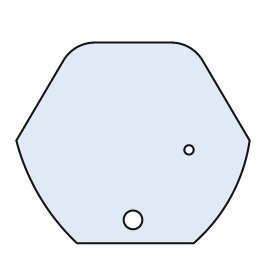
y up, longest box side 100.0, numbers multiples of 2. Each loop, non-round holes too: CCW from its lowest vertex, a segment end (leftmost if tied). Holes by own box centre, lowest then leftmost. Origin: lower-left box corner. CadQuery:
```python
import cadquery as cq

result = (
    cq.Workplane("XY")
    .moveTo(26.0, 0.0)
    .lineTo(76.0, 0.0)
    .threePointArc((92.0, 20.0), (100.0, 44.0))
    .lineTo(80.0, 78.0)
    .threePointArc((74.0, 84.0), (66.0, 86.0))
    .lineTo(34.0, 86.0)
    .threePointArc((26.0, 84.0), (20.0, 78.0))
    .lineTo(0.0, 44.0)
    .threePointArc((10.0, 20.0), (26.0, 0.0))
    .close()
    .moveTo(50.0, 10.0)
    .circle(4.0)
    .moveTo(74.0, 40.0)
    .circle(2.0)
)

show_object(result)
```